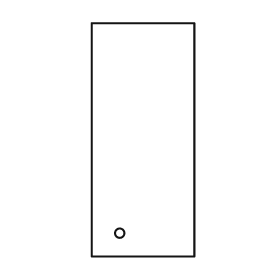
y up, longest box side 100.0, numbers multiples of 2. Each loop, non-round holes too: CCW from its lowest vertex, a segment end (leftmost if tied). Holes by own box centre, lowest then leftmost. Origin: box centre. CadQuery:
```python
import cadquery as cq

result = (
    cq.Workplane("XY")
    .moveTo(-22.0, -50.0)
    .lineTo(22.0, -50.0)
    .lineTo(22.0, 50.0)
    .lineTo(-22.0, 50.0)
    .close()
    .moveTo(-10.0, -40.0)
    .circle(2.0)
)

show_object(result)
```